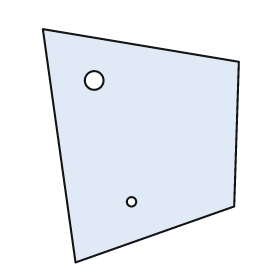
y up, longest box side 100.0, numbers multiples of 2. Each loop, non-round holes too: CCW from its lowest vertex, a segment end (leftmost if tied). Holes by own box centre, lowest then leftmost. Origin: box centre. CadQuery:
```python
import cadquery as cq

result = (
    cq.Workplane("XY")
    .moveTo(-28.0, -50.0)
    .lineTo(40.0, -26.0)
    .lineTo(42.0, 36.0)
    .lineTo(-42.0, 50.0)
    .close()
    .moveTo(-4.0, -24.0)
    .circle(2.0)
    .moveTo(-20.0, 28.0)
    .circle(4.0)
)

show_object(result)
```